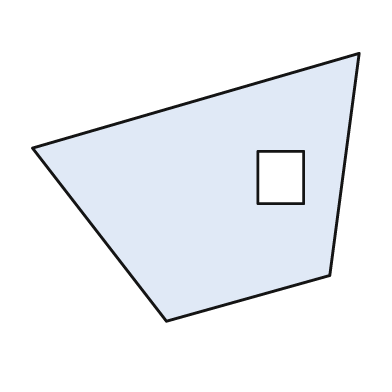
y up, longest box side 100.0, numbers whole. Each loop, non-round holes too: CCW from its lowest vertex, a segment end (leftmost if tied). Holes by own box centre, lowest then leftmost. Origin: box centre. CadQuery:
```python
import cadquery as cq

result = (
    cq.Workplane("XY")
    .moveTo(-9.0, -41.0)
    .lineTo(41.0, -27.0)
    .lineTo(50.0, 41.0)
    .lineTo(-50.0, 12.0)
    .close()
    .moveTo(19.0, -5.0)
    .lineTo(33.0, -5.0)
    .lineTo(33.0, 11.0)
    .lineTo(19.0, 11.0)
    .close()
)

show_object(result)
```